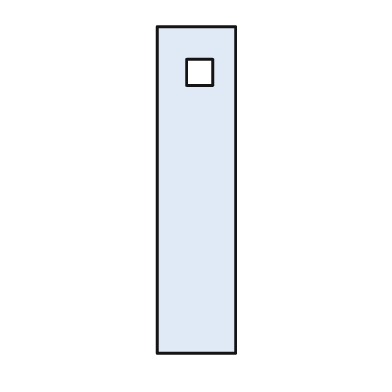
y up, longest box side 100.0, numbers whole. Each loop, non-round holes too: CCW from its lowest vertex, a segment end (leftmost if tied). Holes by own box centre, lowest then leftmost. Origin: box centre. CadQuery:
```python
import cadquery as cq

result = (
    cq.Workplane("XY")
    .moveTo(-12.0, -50.0)
    .lineTo(12.0, -50.0)
    .lineTo(12.0, 50.0)
    .lineTo(-12.0, 50.0)
    .close()
    .moveTo(-3.0, 32.0)
    .lineTo(5.0, 32.0)
    .lineTo(5.0, 40.0)
    .lineTo(-3.0, 40.0)
    .close()
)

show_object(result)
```